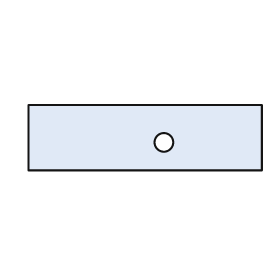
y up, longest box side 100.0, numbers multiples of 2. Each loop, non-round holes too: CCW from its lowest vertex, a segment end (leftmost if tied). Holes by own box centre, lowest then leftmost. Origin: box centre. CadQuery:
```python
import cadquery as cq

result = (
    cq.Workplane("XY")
    .moveTo(-50.0, -14.0)
    .lineTo(50.0, -14.0)
    .lineTo(50.0, 14.0)
    .lineTo(-50.0, 14.0)
    .close()
    .moveTo(8.0, -2.0)
    .circle(4.0)
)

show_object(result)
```